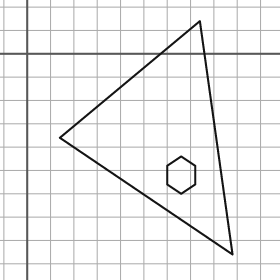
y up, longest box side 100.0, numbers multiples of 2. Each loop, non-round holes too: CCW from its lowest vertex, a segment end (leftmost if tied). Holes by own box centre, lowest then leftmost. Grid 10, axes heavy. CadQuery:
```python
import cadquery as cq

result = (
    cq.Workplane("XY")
    .moveTo(88.0, -86.0)
    .lineTo(74.0, 14.0)
    .lineTo(14.0, -36.0)
    .close()
    .moveTo(66.0, -60.0)
    .lineTo(72.0, -56.0)
    .lineTo(72.0, -48.0)
    .lineTo(66.0, -44.0)
    .lineTo(60.0, -48.0)
    .lineTo(60.0, -56.0)
    .close()
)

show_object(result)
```